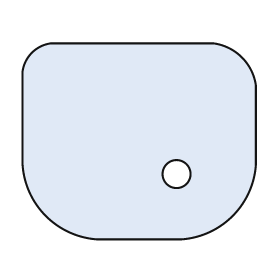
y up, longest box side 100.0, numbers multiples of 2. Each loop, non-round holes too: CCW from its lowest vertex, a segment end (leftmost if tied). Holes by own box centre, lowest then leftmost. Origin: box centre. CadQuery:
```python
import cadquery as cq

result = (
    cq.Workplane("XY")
    .moveTo(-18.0, -42.0)
    .lineTo(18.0, -42.0)
    .threePointArc((40.0, -32.0), (50.0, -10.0))
    .lineTo(50.0, 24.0)
    .threePointArc((44.0, 36.0), (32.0, 42.0))
    .lineTo(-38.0, 42.0)
    .threePointArc((-46.0, 38.0), (-50.0, 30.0))
    .lineTo(-50.0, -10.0)
    .threePointArc((-40.0, -32.0), (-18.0, -42.0))
    .close()
    .moveTo(16.0, -14.0)
    .circle(6.0)
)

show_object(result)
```